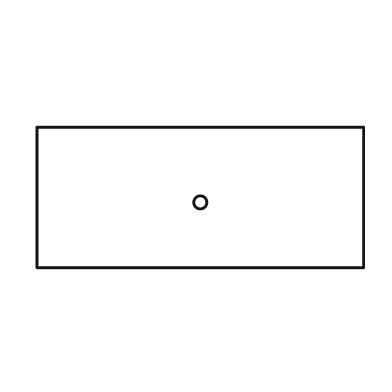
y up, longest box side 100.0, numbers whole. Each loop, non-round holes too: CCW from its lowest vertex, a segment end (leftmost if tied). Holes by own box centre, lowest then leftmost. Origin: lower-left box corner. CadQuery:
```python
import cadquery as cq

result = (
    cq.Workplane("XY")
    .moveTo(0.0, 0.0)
    .lineTo(100.0, 0.0)
    .lineTo(100.0, 43.0)
    .lineTo(0.0, 43.0)
    .close()
    .moveTo(50.0, 20.0)
    .circle(2.0)
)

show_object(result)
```